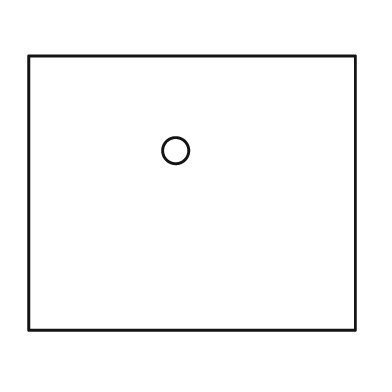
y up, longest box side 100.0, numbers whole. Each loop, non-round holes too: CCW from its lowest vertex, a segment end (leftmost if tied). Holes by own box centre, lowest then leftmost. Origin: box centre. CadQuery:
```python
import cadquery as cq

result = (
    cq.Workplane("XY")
    .moveTo(-50.0, -42.0)
    .lineTo(50.0, -42.0)
    .lineTo(50.0, 42.0)
    .lineTo(-50.0, 42.0)
    .close()
    .moveTo(-5.0, 13.0)
    .circle(4.0)
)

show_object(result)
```